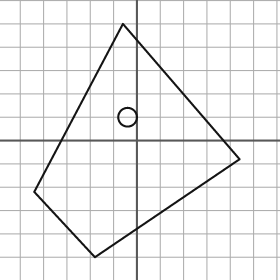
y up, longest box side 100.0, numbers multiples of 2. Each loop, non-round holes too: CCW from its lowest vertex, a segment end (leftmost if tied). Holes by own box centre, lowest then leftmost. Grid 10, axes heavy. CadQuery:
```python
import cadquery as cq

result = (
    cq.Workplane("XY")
    .moveTo(-18.0, -50.0)
    .lineTo(44.0, -8.0)
    .lineTo(-6.0, 50.0)
    .lineTo(-44.0, -22.0)
    .close()
    .moveTo(-4.0, 10.0)
    .circle(4.0)
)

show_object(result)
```